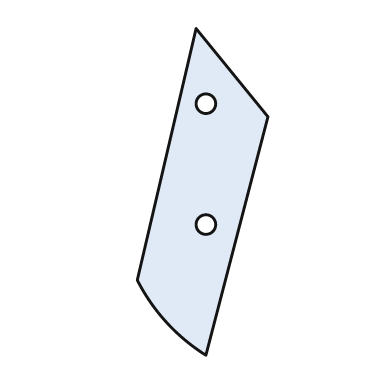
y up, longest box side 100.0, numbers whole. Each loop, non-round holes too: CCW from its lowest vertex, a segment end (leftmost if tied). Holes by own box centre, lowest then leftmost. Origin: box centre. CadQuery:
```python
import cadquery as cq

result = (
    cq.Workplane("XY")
    .moveTo(1.0, -50.0)
    .lineTo(20.0, 23.0)
    .lineTo(-2.0, 50.0)
    .lineTo(-20.0, -27.0)
    .threePointArc((-11.0, -40.0), (1.0, -50.0))
    .close()
    .moveTo(1.0, -10.0)
    .circle(3.0)
    .moveTo(1.0, 27.0)
    .circle(3.0)
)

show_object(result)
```